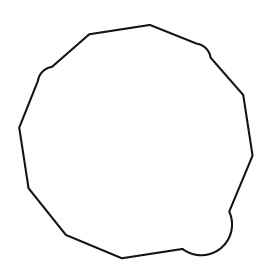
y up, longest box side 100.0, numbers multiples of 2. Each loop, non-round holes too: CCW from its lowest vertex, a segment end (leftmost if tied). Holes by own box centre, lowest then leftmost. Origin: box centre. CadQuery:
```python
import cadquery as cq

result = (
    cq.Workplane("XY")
    .moveTo(-6.0, -50.0)
    .lineTo(20.0, -46.0)
    .threePointArc((36.0, -46.0), (40.0, -30.0))
    .lineTo(50.0, -6.0)
    .lineTo(46.0, 20.0)
    .lineTo(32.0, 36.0)
    .threePointArc((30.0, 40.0), (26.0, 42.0))
    .lineTo(6.0, 50.0)
    .lineTo(-20.0, 46.0)
    .lineTo(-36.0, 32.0)
    .threePointArc((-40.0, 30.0), (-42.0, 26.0))
    .lineTo(-50.0, 6.0)
    .lineTo(-46.0, -20.0)
    .lineTo(-30.0, -40.0)
    .close()
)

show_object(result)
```